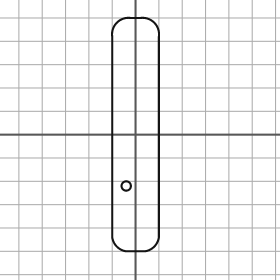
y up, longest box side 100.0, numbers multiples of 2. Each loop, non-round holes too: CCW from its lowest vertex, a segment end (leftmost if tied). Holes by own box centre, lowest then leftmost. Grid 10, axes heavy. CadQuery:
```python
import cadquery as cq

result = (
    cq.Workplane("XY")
    .moveTo(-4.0, -50.0)
    .lineTo(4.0, -50.0)
    .threePointArc((8.0, -48.0), (10.0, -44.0))
    .lineTo(10.0, 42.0)
    .threePointArc((8.0, 48.0), (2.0, 50.0))
    .lineTo(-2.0, 50.0)
    .threePointArc((-8.0, 48.0), (-10.0, 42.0))
    .lineTo(-10.0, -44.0)
    .threePointArc((-8.0, -48.0), (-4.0, -50.0))
    .close()
    .moveTo(-4.0, -22.0)
    .circle(2.0)
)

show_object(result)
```